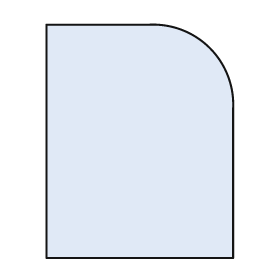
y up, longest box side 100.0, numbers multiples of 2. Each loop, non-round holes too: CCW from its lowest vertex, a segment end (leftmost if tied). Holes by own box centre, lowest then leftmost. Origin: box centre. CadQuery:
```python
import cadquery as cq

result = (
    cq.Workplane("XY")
    .moveTo(-40.0, -50.0)
    .lineTo(40.0, -50.0)
    .lineTo(40.0, 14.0)
    .threePointArc((30.0, 40.0), (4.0, 50.0))
    .lineTo(-40.0, 50.0)
    .close()
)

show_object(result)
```